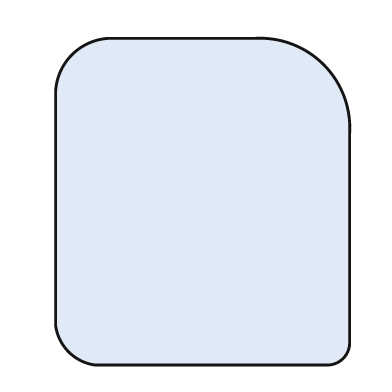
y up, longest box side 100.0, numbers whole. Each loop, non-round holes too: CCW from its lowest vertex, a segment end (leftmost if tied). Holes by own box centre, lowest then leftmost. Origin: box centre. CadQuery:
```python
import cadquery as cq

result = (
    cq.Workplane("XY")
    .moveTo(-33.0, -50.0)
    .lineTo(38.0, -50.0)
    .threePointArc((43.0, -48.0), (45.0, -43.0))
    .lineTo(45.0, 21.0)
    .threePointArc((37.0, 42.0), (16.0, 50.0))
    .lineTo(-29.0, 50.0)
    .threePointArc((-40.0, 45.0), (-45.0, 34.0))
    .lineTo(-45.0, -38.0)
    .threePointArc((-41.0, -46.0), (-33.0, -50.0))
    .close()
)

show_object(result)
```